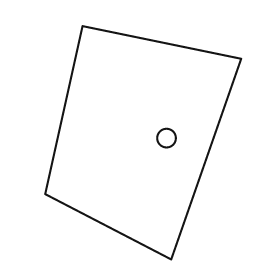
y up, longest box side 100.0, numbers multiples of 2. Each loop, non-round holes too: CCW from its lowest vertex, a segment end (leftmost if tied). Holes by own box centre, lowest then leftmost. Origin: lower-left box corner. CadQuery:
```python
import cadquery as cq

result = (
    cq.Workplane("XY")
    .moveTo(54.0, 0.0)
    .lineTo(84.0, 86.0)
    .lineTo(16.0, 100.0)
    .lineTo(0.0, 28.0)
    .close()
    .moveTo(52.0, 52.0)
    .circle(4.0)
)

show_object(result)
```